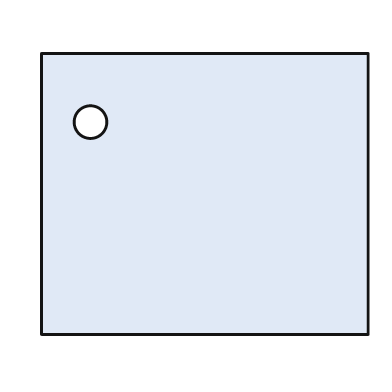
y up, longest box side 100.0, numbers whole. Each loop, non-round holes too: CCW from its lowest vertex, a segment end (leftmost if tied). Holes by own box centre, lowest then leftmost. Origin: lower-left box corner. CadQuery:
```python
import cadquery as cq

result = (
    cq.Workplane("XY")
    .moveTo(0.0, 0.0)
    .lineTo(100.0, 0.0)
    .lineTo(100.0, 86.0)
    .lineTo(0.0, 86.0)
    .close()
    .moveTo(15.0, 65.0)
    .circle(5.0)
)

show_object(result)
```